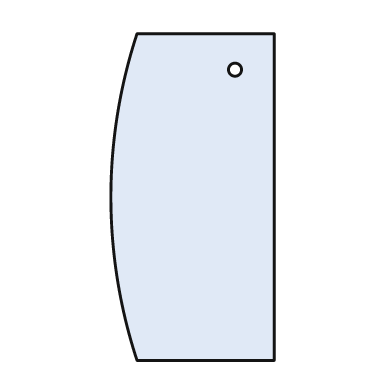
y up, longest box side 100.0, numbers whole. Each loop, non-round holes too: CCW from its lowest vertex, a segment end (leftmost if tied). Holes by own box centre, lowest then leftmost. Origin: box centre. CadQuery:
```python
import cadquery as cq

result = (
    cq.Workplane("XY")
    .moveTo(-17.0, -50.0)
    .lineTo(25.0, -50.0)
    .lineTo(25.0, 50.0)
    .lineTo(-17.0, 50.0)
    .threePointArc((-25.0, 0.0), (-17.0, -50.0))
    .close()
    .moveTo(13.0, 39.0)
    .circle(2.0)
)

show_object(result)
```